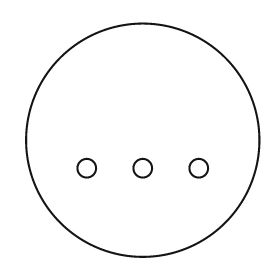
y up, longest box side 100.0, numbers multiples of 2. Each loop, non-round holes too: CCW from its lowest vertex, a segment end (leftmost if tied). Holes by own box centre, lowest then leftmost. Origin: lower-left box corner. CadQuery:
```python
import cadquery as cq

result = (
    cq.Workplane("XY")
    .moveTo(50.0, 50.0)
    .circle(50.0)
    .moveTo(26.0, 38.0)
    .circle(4.0)
    .moveTo(50.0, 38.0)
    .circle(4.0)
    .moveTo(74.0, 38.0)
    .circle(4.0)
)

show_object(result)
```